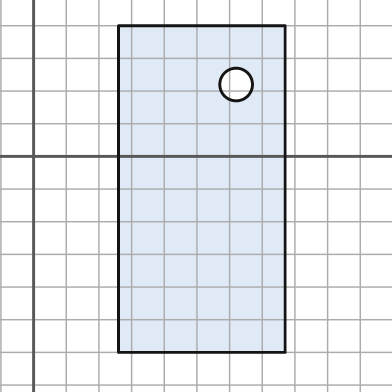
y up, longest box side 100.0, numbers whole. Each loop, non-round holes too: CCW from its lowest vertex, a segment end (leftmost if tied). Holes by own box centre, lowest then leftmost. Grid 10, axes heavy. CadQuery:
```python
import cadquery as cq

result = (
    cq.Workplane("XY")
    .moveTo(26.0, -60.0)
    .lineTo(77.0, -60.0)
    .lineTo(77.0, 40.0)
    .lineTo(26.0, 40.0)
    .close()
    .moveTo(62.0, 22.0)
    .circle(5.0)
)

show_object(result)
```